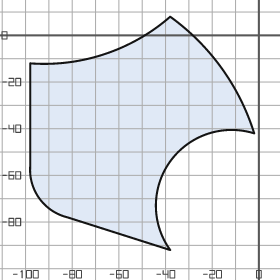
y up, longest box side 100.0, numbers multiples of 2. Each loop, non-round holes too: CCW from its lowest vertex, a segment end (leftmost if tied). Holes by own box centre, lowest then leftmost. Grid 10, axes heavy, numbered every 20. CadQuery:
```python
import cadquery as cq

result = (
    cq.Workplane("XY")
    .moveTo(-38.0, -92.0)
    .threePointArc((-38.0, -54.0), (-2.0, -42.0))
    .threePointArc((-16.0, -14.0), (-38.0, 8.0))
    .threePointArc((-66.0, -8.0), (-98.0, -12.0))
    .lineTo(-98.0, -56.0)
    .threePointArc((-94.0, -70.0), (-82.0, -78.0))
    .close()
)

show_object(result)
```